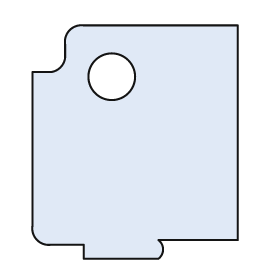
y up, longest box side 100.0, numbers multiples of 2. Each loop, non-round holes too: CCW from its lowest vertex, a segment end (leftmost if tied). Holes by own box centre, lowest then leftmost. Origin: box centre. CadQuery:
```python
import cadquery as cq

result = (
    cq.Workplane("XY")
    .moveTo(-22.0, -50.0)
    .lineTo(10.0, -50.0)
    .threePointArc((12.0, -46.0), (10.0, -42.0))
    .lineTo(44.0, -42.0)
    .lineTo(44.0, 50.0)
    .lineTo(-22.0, 50.0)
    .threePointArc((-28.0, 48.0), (-30.0, 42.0))
    .lineTo(-30.0, 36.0)
    .threePointArc((-32.0, 32.0), (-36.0, 30.0))
    .lineTo(-44.0, 30.0)
    .lineTo(-44.0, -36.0)
    .threePointArc((-42.0, -42.0), (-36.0, -44.0))
    .lineTo(-22.0, -44.0)
    .close()
    .moveTo(-10.0, 28.0)
    .circle(10.0)
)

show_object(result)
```